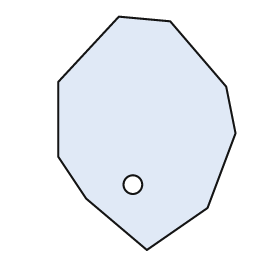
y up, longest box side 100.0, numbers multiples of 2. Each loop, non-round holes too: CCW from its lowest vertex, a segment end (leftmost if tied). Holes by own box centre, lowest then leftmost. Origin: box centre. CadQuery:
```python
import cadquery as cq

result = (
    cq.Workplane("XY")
    .moveTo(0.0, -50.0)
    .lineTo(26.0, -32.0)
    .lineTo(38.0, 0.0)
    .lineTo(34.0, 20.0)
    .lineTo(10.0, 48.0)
    .lineTo(-12.0, 50.0)
    .lineTo(-38.0, 22.0)
    .lineTo(-38.0, -10.0)
    .lineTo(-26.0, -28.0)
    .close()
    .moveTo(-6.0, -22.0)
    .circle(4.0)
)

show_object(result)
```